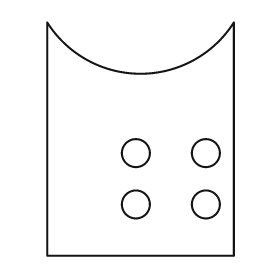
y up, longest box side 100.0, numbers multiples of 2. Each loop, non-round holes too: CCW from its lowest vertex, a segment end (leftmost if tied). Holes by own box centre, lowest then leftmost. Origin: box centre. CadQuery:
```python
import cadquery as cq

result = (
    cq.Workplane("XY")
    .moveTo(-40.0, -50.0)
    .lineTo(40.0, -50.0)
    .lineTo(40.0, 50.0)
    .threePointArc((0.0, 28.0), (-40.0, 50.0))
    .close()
    .moveTo(-2.0, -28.0)
    .circle(6.0)
    .moveTo(28.0, -28.0)
    .circle(6.0)
    .moveTo(-2.0, -6.0)
    .circle(6.0)
    .moveTo(28.0, -6.0)
    .circle(6.0)
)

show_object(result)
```